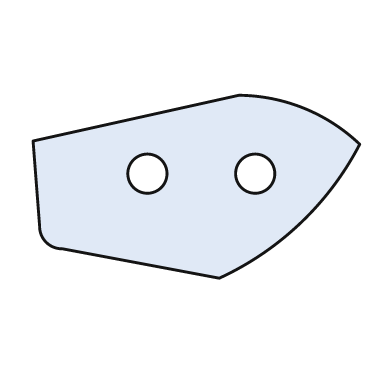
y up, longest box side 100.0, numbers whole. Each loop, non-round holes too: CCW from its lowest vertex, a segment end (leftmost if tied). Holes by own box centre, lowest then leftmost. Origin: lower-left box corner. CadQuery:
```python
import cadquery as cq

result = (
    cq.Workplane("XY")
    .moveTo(57.0, 0.0)
    .threePointArc((82.0, 17.0), (100.0, 41.0))
    .threePointArc((83.0, 52.0), (63.0, 56.0))
    .lineTo(0.0, 42.0)
    .lineTo(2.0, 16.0)
    .threePointArc((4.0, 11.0), (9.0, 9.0))
    .close()
    .moveTo(35.0, 32.0)
    .circle(6.0)
    .moveTo(68.0, 32.0)
    .circle(6.0)
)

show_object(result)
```